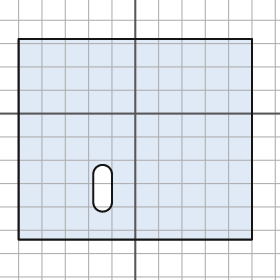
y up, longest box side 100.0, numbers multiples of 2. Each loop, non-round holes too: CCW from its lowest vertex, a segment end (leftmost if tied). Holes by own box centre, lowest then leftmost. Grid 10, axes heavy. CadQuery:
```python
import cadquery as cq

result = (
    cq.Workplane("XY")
    .moveTo(-50.0, -54.0)
    .lineTo(50.0, -54.0)
    .lineTo(50.0, 32.0)
    .lineTo(-50.0, 32.0)
    .close()
    .moveTo(-18.0, -38.0)
    .threePointArc((-14.0, -42.0), (-10.0, -38.0))
    .lineTo(-10.0, -26.0)
    .threePointArc((-14.0, -22.0), (-18.0, -26.0))
    .close()
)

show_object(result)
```